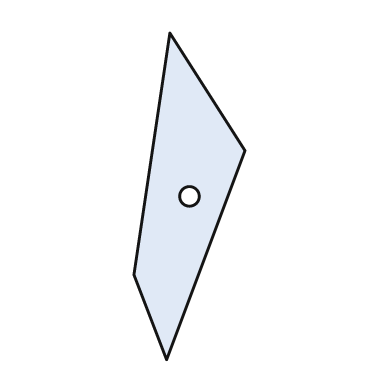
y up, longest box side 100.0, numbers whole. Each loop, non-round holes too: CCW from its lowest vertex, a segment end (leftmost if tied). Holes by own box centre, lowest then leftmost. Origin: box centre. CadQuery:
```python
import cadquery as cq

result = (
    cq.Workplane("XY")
    .moveTo(-7.0, -50.0)
    .lineTo(17.0, 14.0)
    .lineTo(-6.0, 50.0)
    .lineTo(-17.0, -24.0)
    .close()
    .moveTo(0.0, 0.0)
    .circle(3.0)
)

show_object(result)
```